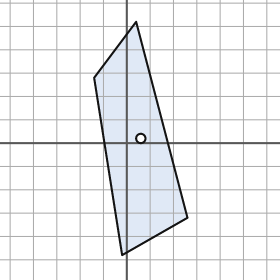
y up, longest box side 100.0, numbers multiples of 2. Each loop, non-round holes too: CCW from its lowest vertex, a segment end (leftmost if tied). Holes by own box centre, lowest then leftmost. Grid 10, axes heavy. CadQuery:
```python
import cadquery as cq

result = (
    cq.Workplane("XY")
    .moveTo(-2.0, -48.0)
    .lineTo(26.0, -32.0)
    .lineTo(4.0, 52.0)
    .lineTo(-14.0, 28.0)
    .close()
    .moveTo(6.0, 2.0)
    .circle(2.0)
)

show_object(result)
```